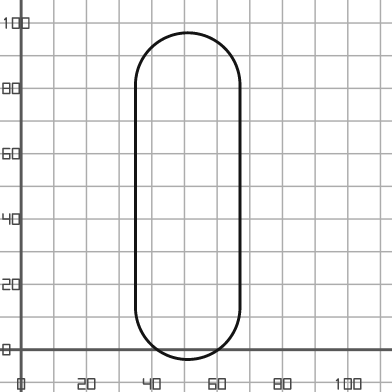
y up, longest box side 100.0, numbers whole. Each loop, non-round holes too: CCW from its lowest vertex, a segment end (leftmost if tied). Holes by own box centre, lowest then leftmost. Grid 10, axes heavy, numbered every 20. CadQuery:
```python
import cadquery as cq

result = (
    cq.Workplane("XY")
    .moveTo(35.0, 13.0)
    .threePointArc((51.0, -3.0), (67.0, 13.0))
    .lineTo(67.0, 81.0)
    .threePointArc((51.0, 97.0), (35.0, 81.0))
    .close()
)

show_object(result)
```